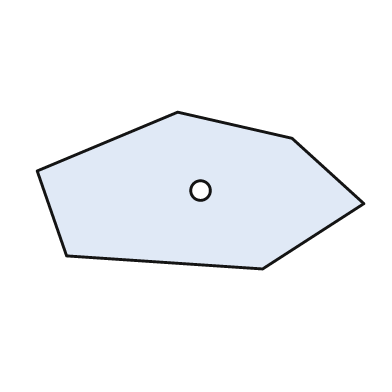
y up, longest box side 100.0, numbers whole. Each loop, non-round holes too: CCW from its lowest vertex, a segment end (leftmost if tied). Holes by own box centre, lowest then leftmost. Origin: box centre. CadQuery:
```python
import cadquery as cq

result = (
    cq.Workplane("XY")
    .moveTo(19.0, -24.0)
    .lineTo(50.0, -4.0)
    .lineTo(28.0, 16.0)
    .lineTo(-7.0, 24.0)
    .lineTo(-50.0, 6.0)
    .lineTo(-41.0, -20.0)
    .close()
    .moveTo(0.0, 0.0)
    .circle(3.0)
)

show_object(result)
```